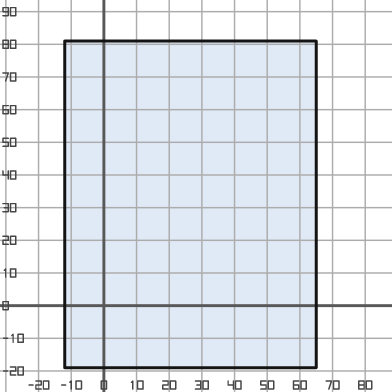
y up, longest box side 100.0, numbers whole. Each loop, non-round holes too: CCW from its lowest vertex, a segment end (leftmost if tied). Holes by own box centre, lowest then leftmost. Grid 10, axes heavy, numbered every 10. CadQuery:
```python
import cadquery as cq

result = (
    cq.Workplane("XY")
    .moveTo(-12.0, -19.0)
    .lineTo(65.0, -19.0)
    .lineTo(65.0, 81.0)
    .lineTo(-12.0, 81.0)
    .close()
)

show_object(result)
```